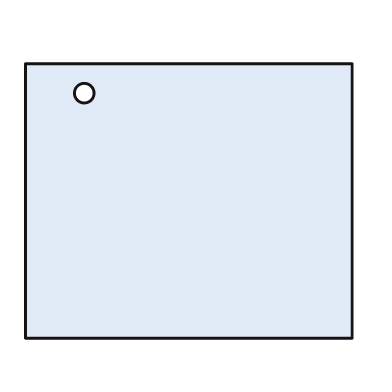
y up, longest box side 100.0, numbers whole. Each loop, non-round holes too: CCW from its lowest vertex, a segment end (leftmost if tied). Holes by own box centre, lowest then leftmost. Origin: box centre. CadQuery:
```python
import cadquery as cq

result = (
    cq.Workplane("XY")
    .moveTo(-50.0, -42.0)
    .lineTo(50.0, -42.0)
    .lineTo(50.0, 42.0)
    .lineTo(-50.0, 42.0)
    .close()
    .moveTo(-32.0, 33.0)
    .circle(3.0)
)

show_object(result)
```